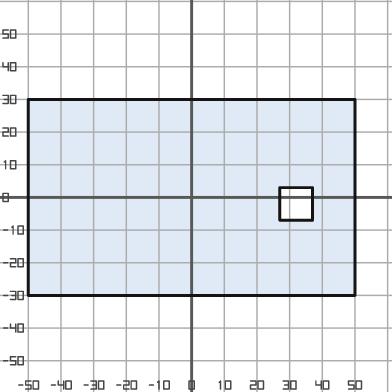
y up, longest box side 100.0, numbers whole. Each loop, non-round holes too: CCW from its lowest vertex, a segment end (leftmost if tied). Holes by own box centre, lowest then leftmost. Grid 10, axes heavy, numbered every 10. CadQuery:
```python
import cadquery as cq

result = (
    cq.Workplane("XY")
    .moveTo(-50.0, -30.0)
    .lineTo(50.0, -30.0)
    .lineTo(50.0, 30.0)
    .lineTo(-50.0, 30.0)
    .close()
    .moveTo(27.0, -7.0)
    .lineTo(37.0, -7.0)
    .lineTo(37.0, 3.0)
    .lineTo(27.0, 3.0)
    .close()
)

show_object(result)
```